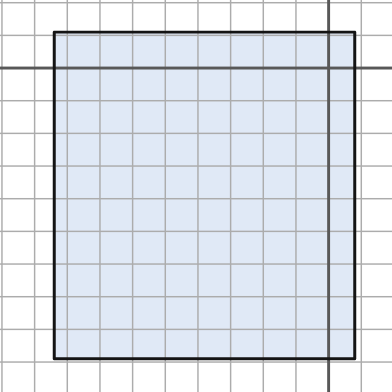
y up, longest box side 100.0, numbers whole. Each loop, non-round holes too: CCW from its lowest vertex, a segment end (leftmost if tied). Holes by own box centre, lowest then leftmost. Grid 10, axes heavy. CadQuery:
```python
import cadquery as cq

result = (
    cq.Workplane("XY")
    .moveTo(-84.0, -89.0)
    .lineTo(8.0, -89.0)
    .lineTo(8.0, 11.0)
    .lineTo(-84.0, 11.0)
    .close()
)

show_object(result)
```